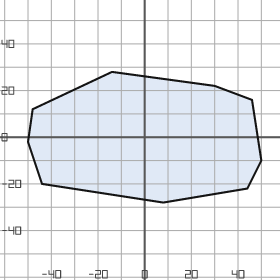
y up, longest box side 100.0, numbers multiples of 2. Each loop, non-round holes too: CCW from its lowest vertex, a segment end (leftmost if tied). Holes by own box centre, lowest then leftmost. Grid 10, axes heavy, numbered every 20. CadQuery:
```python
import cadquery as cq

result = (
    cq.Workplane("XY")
    .moveTo(8.0, -28.0)
    .lineTo(44.0, -22.0)
    .lineTo(50.0, -10.0)
    .lineTo(46.0, 16.0)
    .lineTo(30.0, 22.0)
    .lineTo(-14.0, 28.0)
    .lineTo(-48.0, 12.0)
    .lineTo(-50.0, -2.0)
    .lineTo(-44.0, -20.0)
    .close()
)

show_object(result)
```